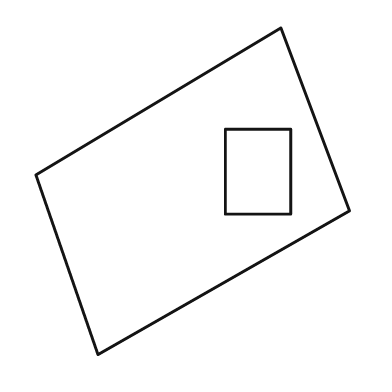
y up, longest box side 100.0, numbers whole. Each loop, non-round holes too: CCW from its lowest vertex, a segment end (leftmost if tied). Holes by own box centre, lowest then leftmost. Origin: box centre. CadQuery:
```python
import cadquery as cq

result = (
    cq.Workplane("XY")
    .moveTo(-29.0, -50.0)
    .lineTo(48.0, -6.0)
    .lineTo(27.0, 50.0)
    .lineTo(-48.0, 5.0)
    .close()
    .moveTo(10.0, -7.0)
    .lineTo(30.0, -7.0)
    .lineTo(30.0, 19.0)
    .lineTo(10.0, 19.0)
    .close()
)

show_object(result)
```